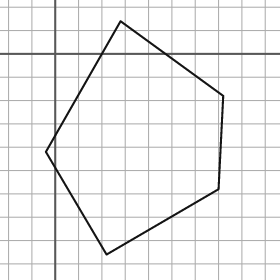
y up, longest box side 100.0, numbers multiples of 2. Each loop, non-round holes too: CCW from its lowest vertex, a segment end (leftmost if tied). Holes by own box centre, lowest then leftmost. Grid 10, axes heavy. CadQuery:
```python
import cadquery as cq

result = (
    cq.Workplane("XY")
    .moveTo(22.0, -86.0)
    .lineTo(70.0, -58.0)
    .lineTo(72.0, -18.0)
    .lineTo(28.0, 14.0)
    .lineTo(-4.0, -42.0)
    .close()
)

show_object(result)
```